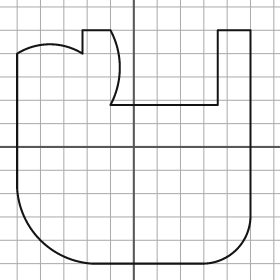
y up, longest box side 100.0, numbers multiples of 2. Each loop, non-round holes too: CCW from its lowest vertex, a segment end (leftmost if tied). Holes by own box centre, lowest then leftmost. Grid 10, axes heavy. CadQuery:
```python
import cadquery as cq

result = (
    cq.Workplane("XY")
    .moveTo(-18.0, -50.0)
    .lineTo(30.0, -50.0)
    .threePointArc((44.0, -44.0), (50.0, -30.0))
    .lineTo(50.0, 50.0)
    .lineTo(36.0, 50.0)
    .lineTo(36.0, 18.0)
    .lineTo(-10.0, 18.0)
    .threePointArc((-6.0, 34.0), (-10.0, 50.0))
    .lineTo(-22.0, 50.0)
    .lineTo(-22.0, 40.0)
    .threePointArc((-36.0, 44.0), (-50.0, 40.0))
    .lineTo(-50.0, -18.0)
    .threePointArc((-40.0, -40.0), (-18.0, -50.0))
    .close()
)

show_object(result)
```